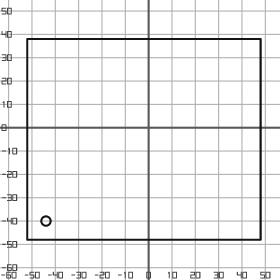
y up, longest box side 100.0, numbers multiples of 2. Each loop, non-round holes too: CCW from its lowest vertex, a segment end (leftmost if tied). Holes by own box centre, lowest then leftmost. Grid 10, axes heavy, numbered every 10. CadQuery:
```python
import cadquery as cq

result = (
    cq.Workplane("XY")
    .moveTo(-52.0, -48.0)
    .lineTo(48.0, -48.0)
    .lineTo(48.0, 38.0)
    .lineTo(-52.0, 38.0)
    .close()
    .moveTo(-44.0, -40.0)
    .circle(2.0)
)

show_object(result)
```